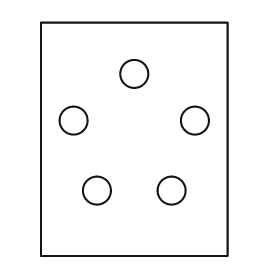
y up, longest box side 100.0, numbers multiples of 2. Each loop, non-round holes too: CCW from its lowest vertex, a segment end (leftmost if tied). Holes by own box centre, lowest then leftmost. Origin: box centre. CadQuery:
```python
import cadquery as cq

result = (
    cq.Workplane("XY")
    .moveTo(-40.0, -50.0)
    .lineTo(40.0, -50.0)
    .lineTo(40.0, 50.0)
    .lineTo(-40.0, 50.0)
    .close()
    .moveTo(-16.0, -22.0)
    .circle(6.0)
    .moveTo(16.0, -22.0)
    .circle(6.0)
    .moveTo(-26.0, 8.0)
    .circle(6.0)
    .moveTo(26.0, 8.0)
    .circle(6.0)
    .moveTo(0.0, 28.0)
    .circle(6.0)
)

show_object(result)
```